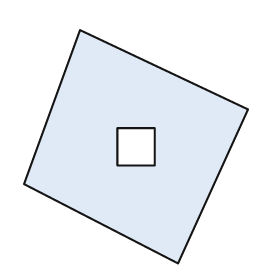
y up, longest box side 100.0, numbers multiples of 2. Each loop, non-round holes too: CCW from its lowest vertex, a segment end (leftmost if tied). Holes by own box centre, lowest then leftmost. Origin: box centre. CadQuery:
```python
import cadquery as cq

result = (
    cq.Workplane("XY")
    .moveTo(18.0, -50.0)
    .lineTo(48.0, 16.0)
    .lineTo(-24.0, 50.0)
    .lineTo(-48.0, -16.0)
    .close()
    .moveTo(-8.0, -8.0)
    .lineTo(8.0, -8.0)
    .lineTo(8.0, 8.0)
    .lineTo(-8.0, 8.0)
    .close()
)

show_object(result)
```